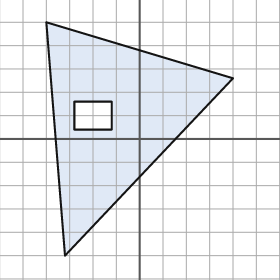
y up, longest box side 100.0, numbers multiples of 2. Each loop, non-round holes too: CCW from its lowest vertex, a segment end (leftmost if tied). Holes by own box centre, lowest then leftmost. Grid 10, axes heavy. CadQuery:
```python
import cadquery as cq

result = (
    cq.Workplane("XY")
    .moveTo(-32.0, -50.0)
    .lineTo(40.0, 26.0)
    .lineTo(-40.0, 50.0)
    .close()
    .moveTo(-28.0, 4.0)
    .lineTo(-12.0, 4.0)
    .lineTo(-12.0, 16.0)
    .lineTo(-28.0, 16.0)
    .close()
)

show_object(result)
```